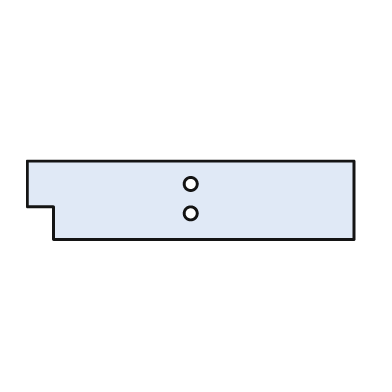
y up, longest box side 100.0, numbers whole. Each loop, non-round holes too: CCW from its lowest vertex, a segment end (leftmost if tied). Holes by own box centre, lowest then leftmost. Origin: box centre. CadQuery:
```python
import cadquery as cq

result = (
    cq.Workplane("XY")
    .moveTo(-42.0, -12.0)
    .lineTo(50.0, -12.0)
    .lineTo(50.0, 12.0)
    .lineTo(-50.0, 12.0)
    .lineTo(-50.0, -2.0)
    .lineTo(-42.0, -2.0)
    .close()
    .moveTo(0.0, -4.0)
    .circle(2.0)
    .moveTo(0.0, 5.0)
    .circle(2.0)
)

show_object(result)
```